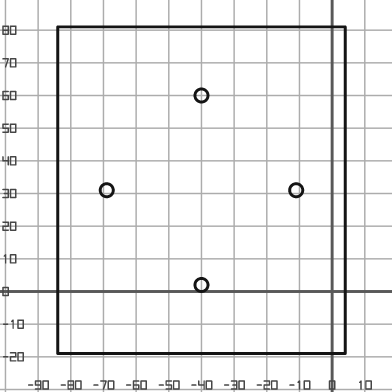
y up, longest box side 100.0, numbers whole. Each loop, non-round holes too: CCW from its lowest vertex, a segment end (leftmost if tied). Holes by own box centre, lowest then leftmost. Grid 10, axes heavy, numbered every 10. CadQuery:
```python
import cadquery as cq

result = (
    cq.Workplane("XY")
    .moveTo(-84.0, -19.0)
    .lineTo(4.0, -19.0)
    .lineTo(4.0, 81.0)
    .lineTo(-84.0, 81.0)
    .close()
    .moveTo(-40.0, 2.0)
    .circle(2.0)
    .moveTo(-69.0, 31.0)
    .circle(2.0)
    .moveTo(-11.0, 31.0)
    .circle(2.0)
    .moveTo(-40.0, 60.0)
    .circle(2.0)
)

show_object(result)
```